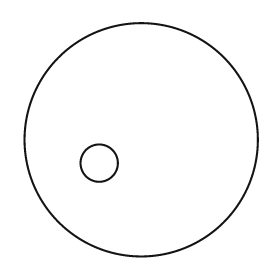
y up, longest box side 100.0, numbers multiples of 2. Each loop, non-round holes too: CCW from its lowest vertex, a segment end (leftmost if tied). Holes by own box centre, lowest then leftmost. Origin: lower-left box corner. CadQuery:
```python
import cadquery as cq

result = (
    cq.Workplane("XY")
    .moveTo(50.0, 50.0)
    .circle(50.0)
    .moveTo(32.0, 40.0)
    .circle(8.0)
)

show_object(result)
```